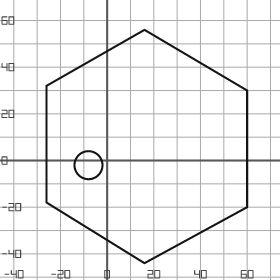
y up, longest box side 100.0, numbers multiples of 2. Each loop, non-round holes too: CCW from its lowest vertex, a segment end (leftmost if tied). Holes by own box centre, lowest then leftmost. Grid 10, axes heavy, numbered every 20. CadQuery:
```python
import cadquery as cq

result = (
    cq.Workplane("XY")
    .moveTo(16.0, -44.0)
    .lineTo(60.0, -20.0)
    .lineTo(60.0, 30.0)
    .lineTo(16.0, 56.0)
    .lineTo(-26.0, 32.0)
    .lineTo(-26.0, -18.0)
    .close()
    .moveTo(-8.0, -2.0)
    .circle(6.0)
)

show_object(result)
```